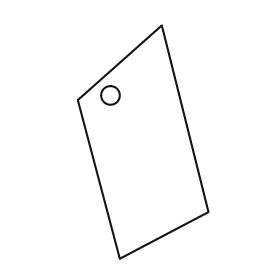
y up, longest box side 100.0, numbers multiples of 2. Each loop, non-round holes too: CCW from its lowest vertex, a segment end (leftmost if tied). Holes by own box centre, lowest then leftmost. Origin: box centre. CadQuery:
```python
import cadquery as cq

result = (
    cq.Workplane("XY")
    .moveTo(-10.0, -50.0)
    .lineTo(28.0, -30.0)
    .lineTo(8.0, 50.0)
    .lineTo(-28.0, 18.0)
    .close()
    .moveTo(-14.0, 20.0)
    .circle(4.0)
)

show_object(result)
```